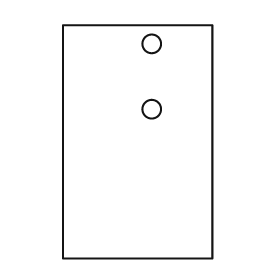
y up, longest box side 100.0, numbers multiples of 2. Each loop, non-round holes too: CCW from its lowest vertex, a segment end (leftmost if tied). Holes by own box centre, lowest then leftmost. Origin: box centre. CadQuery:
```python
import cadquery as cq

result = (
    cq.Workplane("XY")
    .moveTo(-32.0, -50.0)
    .lineTo(32.0, -50.0)
    .lineTo(32.0, 50.0)
    .lineTo(-32.0, 50.0)
    .close()
    .moveTo(6.0, 14.0)
    .circle(4.0)
    .moveTo(6.0, 42.0)
    .circle(4.0)
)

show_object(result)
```